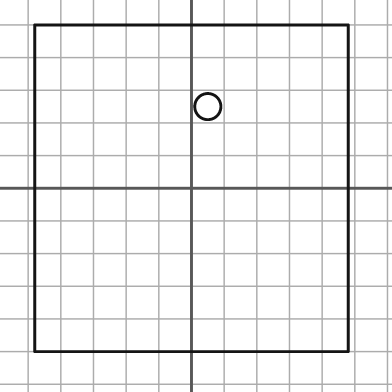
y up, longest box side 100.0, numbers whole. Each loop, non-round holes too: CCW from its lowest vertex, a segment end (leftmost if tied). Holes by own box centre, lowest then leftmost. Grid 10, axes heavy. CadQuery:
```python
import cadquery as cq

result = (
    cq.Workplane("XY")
    .moveTo(-48.0, -50.0)
    .lineTo(48.0, -50.0)
    .lineTo(48.0, 50.0)
    .lineTo(-48.0, 50.0)
    .close()
    .moveTo(5.0, 25.0)
    .circle(4.0)
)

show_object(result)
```